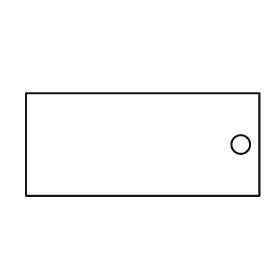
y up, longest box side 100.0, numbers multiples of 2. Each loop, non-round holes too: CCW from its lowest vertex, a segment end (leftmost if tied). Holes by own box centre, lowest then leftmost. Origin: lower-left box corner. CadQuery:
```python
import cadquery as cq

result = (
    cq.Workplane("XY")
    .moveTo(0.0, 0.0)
    .lineTo(100.0, 0.0)
    .lineTo(100.0, 44.0)
    .lineTo(0.0, 44.0)
    .close()
    .moveTo(92.0, 22.0)
    .circle(4.0)
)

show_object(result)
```